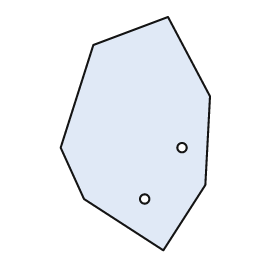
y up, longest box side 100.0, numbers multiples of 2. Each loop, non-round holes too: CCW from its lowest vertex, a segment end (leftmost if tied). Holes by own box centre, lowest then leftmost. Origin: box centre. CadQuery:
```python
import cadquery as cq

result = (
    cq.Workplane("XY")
    .moveTo(12.0, -50.0)
    .lineTo(30.0, -22.0)
    .lineTo(32.0, 16.0)
    .lineTo(14.0, 50.0)
    .lineTo(-18.0, 38.0)
    .lineTo(-32.0, -6.0)
    .lineTo(-22.0, -28.0)
    .close()
    .moveTo(4.0, -28.0)
    .circle(2.0)
    .moveTo(20.0, -6.0)
    .circle(2.0)
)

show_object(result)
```